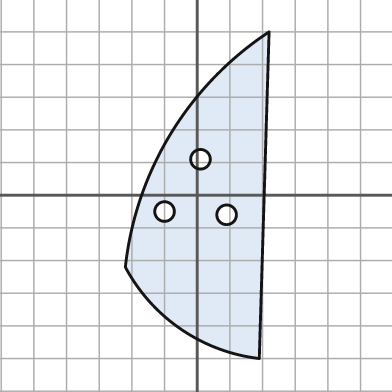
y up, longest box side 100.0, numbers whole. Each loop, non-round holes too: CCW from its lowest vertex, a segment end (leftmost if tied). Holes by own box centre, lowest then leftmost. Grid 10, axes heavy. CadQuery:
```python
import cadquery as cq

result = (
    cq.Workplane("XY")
    .moveTo(19.0, -50.0)
    .lineTo(22.0, 50.0)
    .threePointArc((-8.0, 19.0), (-22.0, -22.0))
    .threePointArc((-5.0, -41.0), (19.0, -50.0))
    .close()
    .moveTo(9.0, -6.0)
    .circle(3.0)
    .moveTo(-10.0, -5.0)
    .circle(3.0)
    .moveTo(1.0, 11.0)
    .circle(3.0)
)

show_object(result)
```